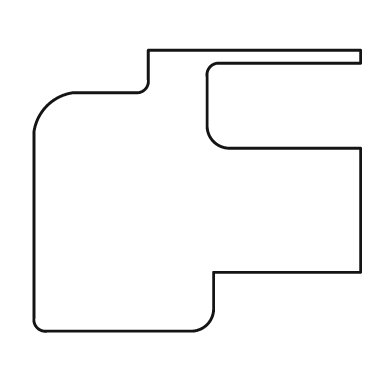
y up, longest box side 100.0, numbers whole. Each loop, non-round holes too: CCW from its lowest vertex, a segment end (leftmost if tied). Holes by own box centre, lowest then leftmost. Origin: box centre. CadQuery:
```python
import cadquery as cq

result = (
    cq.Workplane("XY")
    .moveTo(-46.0, -43.0)
    .lineTo(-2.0, -43.0)
    .threePointArc((3.0, -41.0), (5.0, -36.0))
    .lineTo(5.0, -25.0)
    .lineTo(50.0, -25.0)
    .lineTo(50.0, 13.0)
    .lineTo(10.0, 13.0)
    .threePointArc((5.0, 15.0), (3.0, 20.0))
    .lineTo(3.0, 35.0)
    .threePointArc((4.0, 38.0), (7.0, 39.0))
    .lineTo(50.0, 39.0)
    .lineTo(50.0, 43.0)
    .lineTo(-15.0, 43.0)
    .lineTo(-15.0, 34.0)
    .threePointArc((-16.0, 31.0), (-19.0, 30.0))
    .lineTo(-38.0, 30.0)
    .threePointArc((-46.0, 26.0), (-50.0, 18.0))
    .lineTo(-50.0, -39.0)
    .threePointArc((-49.0, -42.0), (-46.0, -43.0))
    .close()
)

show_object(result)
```